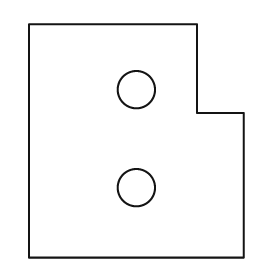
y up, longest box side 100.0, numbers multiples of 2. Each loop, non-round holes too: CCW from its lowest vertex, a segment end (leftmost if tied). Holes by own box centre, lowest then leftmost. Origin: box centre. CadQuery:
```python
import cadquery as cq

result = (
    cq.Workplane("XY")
    .moveTo(-46.0, -50.0)
    .lineTo(46.0, -50.0)
    .lineTo(46.0, 12.0)
    .lineTo(26.0, 12.0)
    .lineTo(26.0, 50.0)
    .lineTo(-46.0, 50.0)
    .close()
    .moveTo(0.0, -20.0)
    .circle(8.0)
    .moveTo(0.0, 22.0)
    .circle(8.0)
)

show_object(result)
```